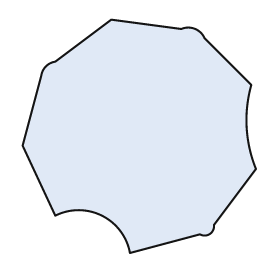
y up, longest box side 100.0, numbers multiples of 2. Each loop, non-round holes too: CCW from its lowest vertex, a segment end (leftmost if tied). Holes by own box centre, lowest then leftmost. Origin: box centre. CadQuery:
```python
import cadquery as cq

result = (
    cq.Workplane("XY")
    .moveTo(-4.0, -50.0)
    .lineTo(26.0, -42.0)
    .threePointArc((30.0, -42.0), (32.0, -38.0))
    .lineTo(50.0, -14.0)
    .threePointArc((46.0, 4.0), (48.0, 22.0))
    .lineTo(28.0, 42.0)
    .threePointArc((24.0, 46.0), (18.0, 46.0))
    .lineTo(-12.0, 50.0)
    .lineTo(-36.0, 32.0)
    .threePointArc((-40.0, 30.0), (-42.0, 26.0))
    .lineTo(-50.0, -4.0)
    .lineTo(-36.0, -34.0)
    .threePointArc((-16.0, -34.0), (-4.0, -50.0))
    .close()
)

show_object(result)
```